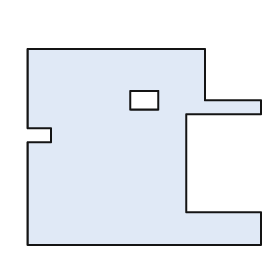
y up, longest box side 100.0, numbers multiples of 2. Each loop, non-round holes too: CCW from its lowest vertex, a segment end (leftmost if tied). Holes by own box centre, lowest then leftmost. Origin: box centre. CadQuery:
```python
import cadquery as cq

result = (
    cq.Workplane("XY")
    .moveTo(-50.0, -42.0)
    .lineTo(50.0, -42.0)
    .lineTo(50.0, -28.0)
    .lineTo(18.0, -28.0)
    .lineTo(18.0, 14.0)
    .lineTo(50.0, 14.0)
    .lineTo(50.0, 20.0)
    .lineTo(26.0, 20.0)
    .lineTo(26.0, 42.0)
    .lineTo(-50.0, 42.0)
    .lineTo(-50.0, 8.0)
    .lineTo(-40.0, 8.0)
    .lineTo(-40.0, 2.0)
    .lineTo(-50.0, 2.0)
    .close()
    .moveTo(-6.0, 16.0)
    .lineTo(6.0, 16.0)
    .lineTo(6.0, 24.0)
    .lineTo(-6.0, 24.0)
    .close()
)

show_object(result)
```